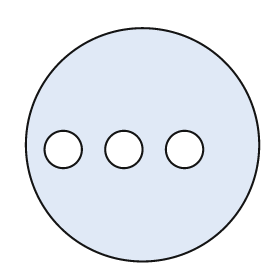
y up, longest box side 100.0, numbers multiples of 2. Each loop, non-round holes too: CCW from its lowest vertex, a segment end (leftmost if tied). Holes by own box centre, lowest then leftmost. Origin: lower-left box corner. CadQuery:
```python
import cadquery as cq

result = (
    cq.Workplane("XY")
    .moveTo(50.0, 50.0)
    .circle(50.0)
    .moveTo(16.0, 48.0)
    .circle(8.0)
    .moveTo(42.0, 48.0)
    .circle(8.0)
    .moveTo(68.0, 48.0)
    .circle(8.0)
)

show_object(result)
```